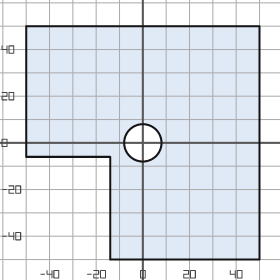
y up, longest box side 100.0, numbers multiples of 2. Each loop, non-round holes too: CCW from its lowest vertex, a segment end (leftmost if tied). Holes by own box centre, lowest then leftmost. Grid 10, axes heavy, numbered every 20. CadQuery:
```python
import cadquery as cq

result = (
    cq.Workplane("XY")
    .moveTo(-14.0, -50.0)
    .lineTo(50.0, -50.0)
    .lineTo(50.0, 50.0)
    .lineTo(-50.0, 50.0)
    .lineTo(-50.0, -6.0)
    .lineTo(-14.0, -6.0)
    .close()
    .moveTo(0.0, 0.0)
    .circle(8.0)
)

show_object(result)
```